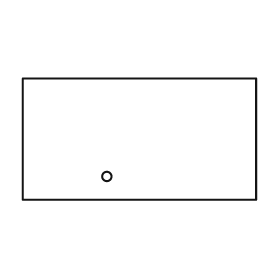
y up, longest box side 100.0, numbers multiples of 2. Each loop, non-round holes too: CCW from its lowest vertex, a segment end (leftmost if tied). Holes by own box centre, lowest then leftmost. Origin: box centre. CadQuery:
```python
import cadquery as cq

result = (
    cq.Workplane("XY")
    .moveTo(-50.0, -26.0)
    .lineTo(50.0, -26.0)
    .lineTo(50.0, 26.0)
    .lineTo(-50.0, 26.0)
    .close()
    .moveTo(-14.0, -16.0)
    .circle(2.0)
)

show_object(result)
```